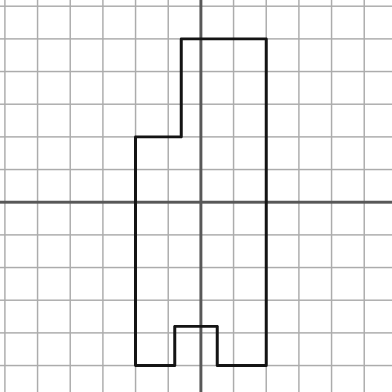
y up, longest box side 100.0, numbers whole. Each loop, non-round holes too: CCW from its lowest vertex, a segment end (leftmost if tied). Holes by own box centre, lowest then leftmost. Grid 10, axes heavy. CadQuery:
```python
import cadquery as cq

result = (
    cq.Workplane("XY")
    .moveTo(-20.0, -50.0)
    .lineTo(-8.0, -50.0)
    .lineTo(-8.0, -38.0)
    .lineTo(5.0, -38.0)
    .lineTo(5.0, -50.0)
    .lineTo(20.0, -50.0)
    .lineTo(20.0, 50.0)
    .lineTo(-6.0, 50.0)
    .lineTo(-6.0, 20.0)
    .lineTo(-20.0, 20.0)
    .close()
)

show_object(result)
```